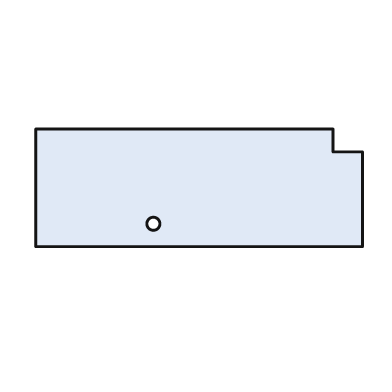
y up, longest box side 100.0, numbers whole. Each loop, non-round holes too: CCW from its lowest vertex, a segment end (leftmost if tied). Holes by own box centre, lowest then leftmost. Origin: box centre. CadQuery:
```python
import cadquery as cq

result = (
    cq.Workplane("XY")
    .moveTo(-50.0, -18.0)
    .lineTo(50.0, -18.0)
    .lineTo(50.0, 11.0)
    .lineTo(41.0, 11.0)
    .lineTo(41.0, 18.0)
    .lineTo(-50.0, 18.0)
    .close()
    .moveTo(-14.0, -11.0)
    .circle(2.0)
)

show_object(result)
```